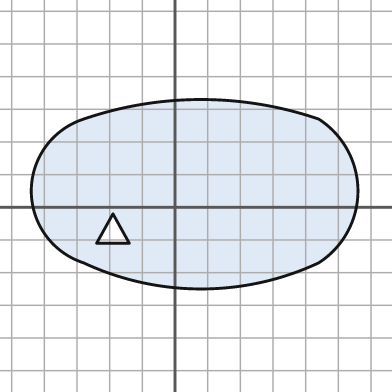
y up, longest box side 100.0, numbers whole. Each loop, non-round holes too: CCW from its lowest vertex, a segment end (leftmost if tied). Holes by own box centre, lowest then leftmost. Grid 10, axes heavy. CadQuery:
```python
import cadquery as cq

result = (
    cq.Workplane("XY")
    .moveTo(-28.0, -17.0)
    .threePointArc((8.0, -25.0), (44.0, -17.0))
    .threePointArc((56.0, 5.0), (44.0, 27.0))
    .threePointArc((8.0, 33.0), (-28.0, 27.0))
    .threePointArc((-44.0, 5.0), (-28.0, -17.0))
    .close()
    .moveTo(-24.0, -11.0)
    .lineTo(-14.0, -11.0)
    .lineTo(-19.0, -2.0)
    .close()
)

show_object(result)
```